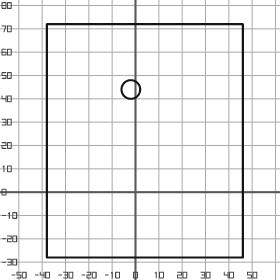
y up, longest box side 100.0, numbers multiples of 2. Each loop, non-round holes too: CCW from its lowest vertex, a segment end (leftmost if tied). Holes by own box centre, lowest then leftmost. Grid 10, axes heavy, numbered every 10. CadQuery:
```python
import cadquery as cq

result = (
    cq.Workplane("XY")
    .moveTo(-38.0, -28.0)
    .lineTo(46.0, -28.0)
    .lineTo(46.0, 72.0)
    .lineTo(-38.0, 72.0)
    .close()
    .moveTo(-2.0, 44.0)
    .circle(4.0)
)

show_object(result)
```